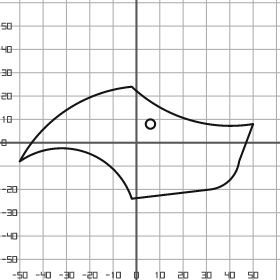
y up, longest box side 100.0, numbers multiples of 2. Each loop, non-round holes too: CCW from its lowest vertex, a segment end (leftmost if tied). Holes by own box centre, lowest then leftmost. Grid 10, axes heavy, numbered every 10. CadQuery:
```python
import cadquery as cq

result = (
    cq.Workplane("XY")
    .moveTo(-2.0, -24.0)
    .lineTo(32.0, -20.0)
    .threePointArc((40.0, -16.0), (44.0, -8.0))
    .lineTo(50.0, 8.0)
    .threePointArc((22.0, 10.0), (-2.0, 24.0))
    .threePointArc((-30.0, 14.0), (-50.0, -8.0))
    .threePointArc((-22.0, -4.0), (-2.0, -24.0))
    .close()
    .moveTo(6.0, 8.0)
    .circle(2.0)
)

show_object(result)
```